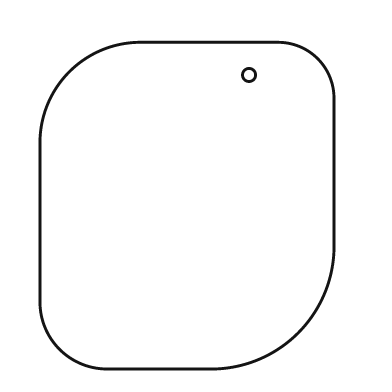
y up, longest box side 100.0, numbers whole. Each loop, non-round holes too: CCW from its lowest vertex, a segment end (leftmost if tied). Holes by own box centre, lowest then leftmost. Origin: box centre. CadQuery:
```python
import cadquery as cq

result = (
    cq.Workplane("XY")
    .moveTo(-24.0, -50.0)
    .lineTo(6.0, -50.0)
    .threePointArc((34.0, -39.0), (45.0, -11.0))
    .lineTo(45.0, 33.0)
    .threePointArc((40.0, 45.0), (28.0, 50.0))
    .lineTo(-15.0, 50.0)
    .threePointArc((-36.0, 41.0), (-45.0, 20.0))
    .lineTo(-45.0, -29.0)
    .threePointArc((-39.0, -44.0), (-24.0, -50.0))
    .close()
    .moveTo(19.0, 40.0)
    .circle(2.0)
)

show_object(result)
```